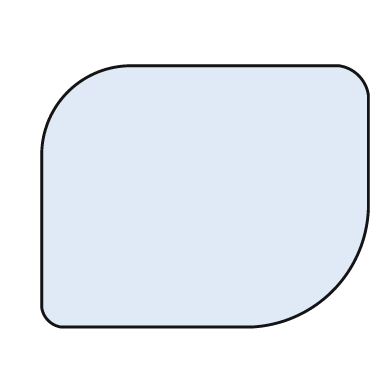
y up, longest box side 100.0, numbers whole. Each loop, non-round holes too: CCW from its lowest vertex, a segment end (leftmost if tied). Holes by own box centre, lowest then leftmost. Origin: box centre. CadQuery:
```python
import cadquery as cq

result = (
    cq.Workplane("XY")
    .moveTo(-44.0, -40.0)
    .lineTo(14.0, -40.0)
    .threePointArc((39.0, -29.0), (50.0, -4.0))
    .lineTo(50.0, 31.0)
    .threePointArc((47.0, 37.0), (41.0, 40.0))
    .lineTo(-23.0, 40.0)
    .threePointArc((-42.0, 32.0), (-50.0, 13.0))
    .lineTo(-50.0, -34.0)
    .threePointArc((-48.0, -38.0), (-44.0, -40.0))
    .close()
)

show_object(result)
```